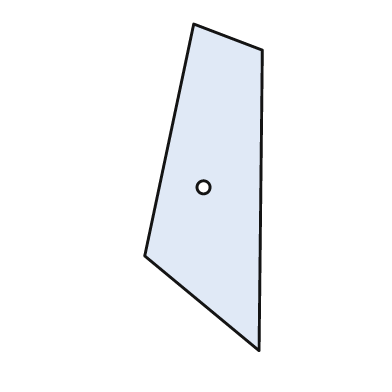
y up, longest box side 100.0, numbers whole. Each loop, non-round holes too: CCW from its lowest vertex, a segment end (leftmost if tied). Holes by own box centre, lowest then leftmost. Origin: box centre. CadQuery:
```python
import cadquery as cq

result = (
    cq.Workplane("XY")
    .moveTo(17.0, -50.0)
    .lineTo(18.0, 42.0)
    .lineTo(-3.0, 50.0)
    .lineTo(-18.0, -21.0)
    .close()
    .moveTo(0.0, 0.0)
    .circle(2.0)
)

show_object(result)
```